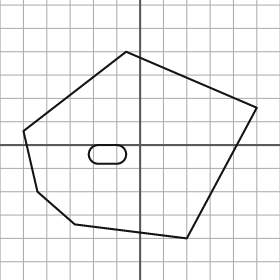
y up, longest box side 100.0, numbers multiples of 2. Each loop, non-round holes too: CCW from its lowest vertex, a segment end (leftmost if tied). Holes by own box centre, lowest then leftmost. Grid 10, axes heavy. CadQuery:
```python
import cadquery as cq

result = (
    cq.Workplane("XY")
    .moveTo(20.0, -40.0)
    .lineTo(50.0, 16.0)
    .lineTo(-6.0, 40.0)
    .lineTo(-50.0, 6.0)
    .lineTo(-44.0, -20.0)
    .lineTo(-28.0, -34.0)
    .close()
    .moveTo(-18.0, -8.0)
    .lineTo(-10.0, -8.0)
    .threePointArc((-6.0, -4.0), (-10.0, 0.0))
    .lineTo(-18.0, 0.0)
    .threePointArc((-22.0, -4.0), (-18.0, -8.0))
    .close()
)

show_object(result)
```